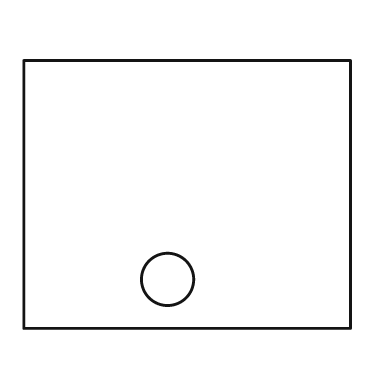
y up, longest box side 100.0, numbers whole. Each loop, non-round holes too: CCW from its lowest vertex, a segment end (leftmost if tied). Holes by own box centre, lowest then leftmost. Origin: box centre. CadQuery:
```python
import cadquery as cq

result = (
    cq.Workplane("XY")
    .moveTo(-50.0, -41.0)
    .lineTo(50.0, -41.0)
    .lineTo(50.0, 41.0)
    .lineTo(-50.0, 41.0)
    .close()
    .moveTo(-6.0, -26.0)
    .circle(8.0)
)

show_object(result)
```